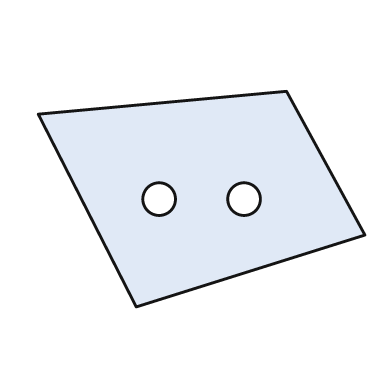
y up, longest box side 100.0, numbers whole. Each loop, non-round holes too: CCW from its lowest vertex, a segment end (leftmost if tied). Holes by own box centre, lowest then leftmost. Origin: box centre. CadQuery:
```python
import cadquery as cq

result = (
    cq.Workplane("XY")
    .moveTo(-20.0, -33.0)
    .lineTo(50.0, -11.0)
    .lineTo(26.0, 33.0)
    .lineTo(-50.0, 26.0)
    .close()
    .moveTo(-13.0, 0.0)
    .circle(5.0)
    .moveTo(13.0, 0.0)
    .circle(5.0)
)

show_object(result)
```